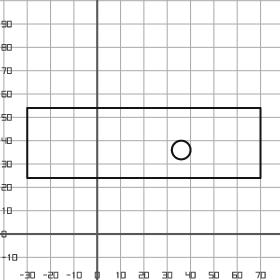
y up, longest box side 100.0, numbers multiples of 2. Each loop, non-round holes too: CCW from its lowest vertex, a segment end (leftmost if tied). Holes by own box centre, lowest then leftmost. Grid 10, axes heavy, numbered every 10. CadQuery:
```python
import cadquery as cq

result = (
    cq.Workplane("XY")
    .moveTo(-30.0, 24.0)
    .lineTo(70.0, 24.0)
    .lineTo(70.0, 54.0)
    .lineTo(-30.0, 54.0)
    .close()
    .moveTo(36.0, 36.0)
    .circle(4.0)
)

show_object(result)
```